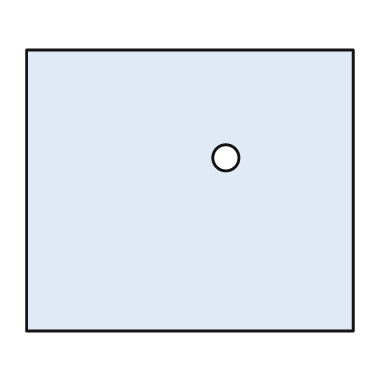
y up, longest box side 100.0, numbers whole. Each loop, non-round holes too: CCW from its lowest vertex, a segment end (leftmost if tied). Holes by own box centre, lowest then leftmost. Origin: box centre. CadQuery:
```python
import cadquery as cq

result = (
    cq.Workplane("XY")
    .moveTo(-50.0, -43.0)
    .lineTo(50.0, -43.0)
    .lineTo(50.0, 43.0)
    .lineTo(-50.0, 43.0)
    .close()
    .moveTo(11.0, 10.0)
    .circle(4.0)
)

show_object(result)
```